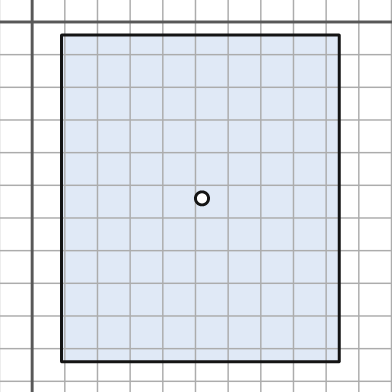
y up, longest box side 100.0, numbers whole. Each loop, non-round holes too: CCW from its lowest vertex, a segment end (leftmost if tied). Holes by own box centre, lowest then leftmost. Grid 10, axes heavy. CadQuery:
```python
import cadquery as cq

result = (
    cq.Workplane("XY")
    .moveTo(9.0, -104.0)
    .lineTo(94.0, -104.0)
    .lineTo(94.0, -4.0)
    .lineTo(9.0, -4.0)
    .close()
    .moveTo(52.0, -54.0)
    .circle(2.0)
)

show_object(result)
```